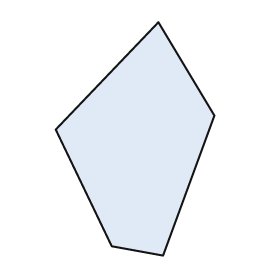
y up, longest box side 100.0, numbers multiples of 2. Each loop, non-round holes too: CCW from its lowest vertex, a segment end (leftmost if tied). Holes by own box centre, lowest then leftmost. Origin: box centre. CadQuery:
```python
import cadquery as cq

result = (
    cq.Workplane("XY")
    .moveTo(12.0, -50.0)
    .lineTo(34.0, 10.0)
    .lineTo(10.0, 50.0)
    .lineTo(-34.0, 4.0)
    .lineTo(-10.0, -46.0)
    .close()
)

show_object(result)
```